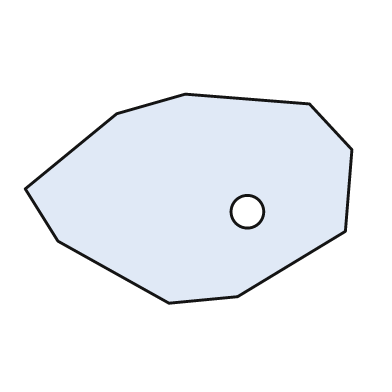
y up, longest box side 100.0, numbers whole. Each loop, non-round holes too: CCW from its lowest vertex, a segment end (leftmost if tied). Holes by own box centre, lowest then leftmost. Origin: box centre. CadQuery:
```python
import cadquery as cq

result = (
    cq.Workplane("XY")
    .moveTo(-6.0, -32.0)
    .lineTo(15.0, -30.0)
    .lineTo(48.0, -10.0)
    .lineTo(50.0, 15.0)
    .lineTo(37.0, 29.0)
    .lineTo(-1.0, 32.0)
    .lineTo(-22.0, 26.0)
    .lineTo(-50.0, 3.0)
    .lineTo(-40.0, -13.0)
    .close()
    .moveTo(18.0, -4.0)
    .circle(5.0)
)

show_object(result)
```